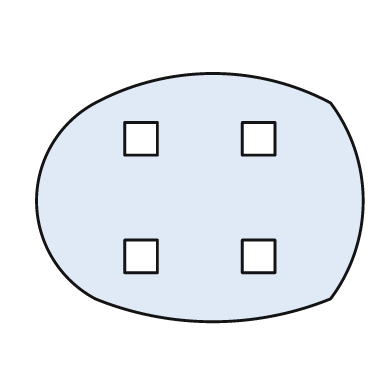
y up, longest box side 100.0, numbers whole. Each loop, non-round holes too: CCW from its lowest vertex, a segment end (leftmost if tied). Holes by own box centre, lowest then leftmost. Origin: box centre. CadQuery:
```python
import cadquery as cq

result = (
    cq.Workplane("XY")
    .moveTo(-32.0, -31.0)
    .threePointArc((4.0, -38.0), (40.0, -31.0))
    .threePointArc((50.0, -1.0), (40.0, 29.0))
    .threePointArc((4.0, 38.0), (-32.0, 29.0))
    .threePointArc((-50.0, -1.0), (-32.0, -31.0))
    .close()
    .moveTo(-23.0, -23.0)
    .lineTo(-13.0, -23.0)
    .lineTo(-13.0, -13.0)
    .lineTo(-23.0, -13.0)
    .close()
    .moveTo(13.0, -23.0)
    .lineTo(23.0, -23.0)
    .lineTo(23.0, -13.0)
    .lineTo(13.0, -13.0)
    .close()
    .moveTo(-23.0, 13.0)
    .lineTo(-13.0, 13.0)
    .lineTo(-13.0, 23.0)
    .lineTo(-23.0, 23.0)
    .close()
    .moveTo(13.0, 13.0)
    .lineTo(23.0, 13.0)
    .lineTo(23.0, 23.0)
    .lineTo(13.0, 23.0)
    .close()
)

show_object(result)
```